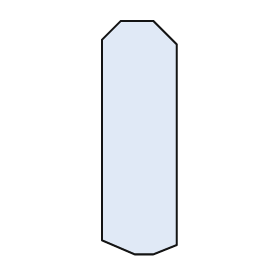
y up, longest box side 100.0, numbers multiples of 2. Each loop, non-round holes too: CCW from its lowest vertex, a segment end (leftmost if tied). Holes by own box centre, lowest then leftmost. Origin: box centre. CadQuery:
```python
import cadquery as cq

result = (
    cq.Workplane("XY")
    .moveTo(-2.0, -50.0)
    .lineTo(6.0, -50.0)
    .lineTo(16.0, -46.0)
    .lineTo(16.0, 40.0)
    .lineTo(6.0, 50.0)
    .lineTo(-8.0, 50.0)
    .lineTo(-16.0, 42.0)
    .lineTo(-16.0, -44.0)
    .close()
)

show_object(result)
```